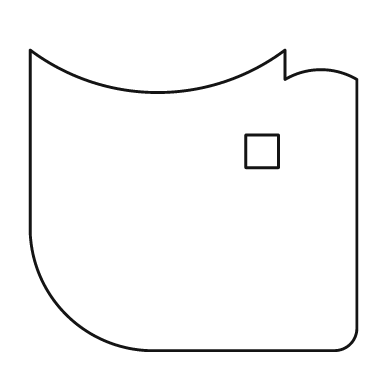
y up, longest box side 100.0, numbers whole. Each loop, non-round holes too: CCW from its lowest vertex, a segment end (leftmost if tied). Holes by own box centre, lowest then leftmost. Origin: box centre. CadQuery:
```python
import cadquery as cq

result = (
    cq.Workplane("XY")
    .moveTo(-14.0, -46.0)
    .lineTo(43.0, -46.0)
    .threePointArc((48.0, -44.0), (50.0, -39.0))
    .lineTo(50.0, 37.0)
    .threePointArc((39.0, 40.0), (28.0, 37.0))
    .lineTo(28.0, 46.0)
    .threePointArc((-11.0, 33.0), (-50.0, 46.0))
    .lineTo(-50.0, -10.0)
    .threePointArc((-39.0, -35.0), (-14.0, -46.0))
    .close()
    .moveTo(16.0, 10.0)
    .lineTo(26.0, 10.0)
    .lineTo(26.0, 20.0)
    .lineTo(16.0, 20.0)
    .close()
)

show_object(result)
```